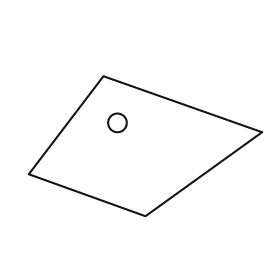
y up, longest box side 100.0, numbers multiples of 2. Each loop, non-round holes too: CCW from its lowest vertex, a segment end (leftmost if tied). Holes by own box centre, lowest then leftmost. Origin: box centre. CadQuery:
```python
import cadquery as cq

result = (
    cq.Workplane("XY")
    .moveTo(0.0, -30.0)
    .lineTo(50.0, 6.0)
    .lineTo(-18.0, 30.0)
    .lineTo(-50.0, -12.0)
    .close()
    .moveTo(-12.0, 10.0)
    .circle(4.0)
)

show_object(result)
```